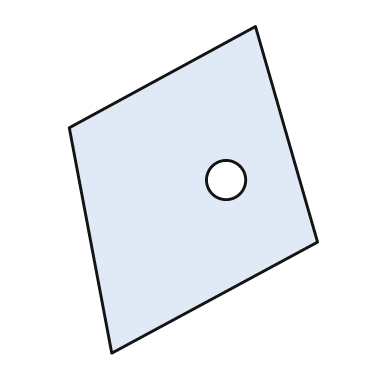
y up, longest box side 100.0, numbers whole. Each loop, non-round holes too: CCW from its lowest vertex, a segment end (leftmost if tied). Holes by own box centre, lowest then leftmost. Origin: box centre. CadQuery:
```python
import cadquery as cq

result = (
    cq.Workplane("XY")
    .moveTo(-25.0, -50.0)
    .lineTo(38.0, -16.0)
    .lineTo(19.0, 50.0)
    .lineTo(-38.0, 19.0)
    .close()
    .moveTo(10.0, 3.0)
    .circle(6.0)
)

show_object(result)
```